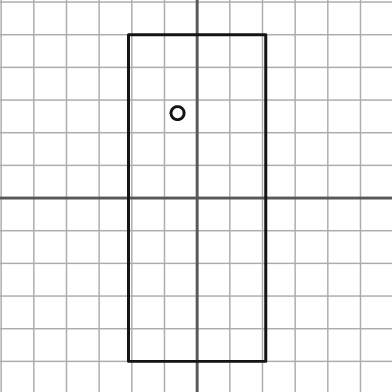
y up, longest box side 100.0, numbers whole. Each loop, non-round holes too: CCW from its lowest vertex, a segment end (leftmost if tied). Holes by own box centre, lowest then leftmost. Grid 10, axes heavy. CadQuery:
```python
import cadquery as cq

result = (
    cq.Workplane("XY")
    .moveTo(-21.0, -50.0)
    .lineTo(21.0, -50.0)
    .lineTo(21.0, 50.0)
    .lineTo(-21.0, 50.0)
    .close()
    .moveTo(-6.0, 26.0)
    .circle(2.0)
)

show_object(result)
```